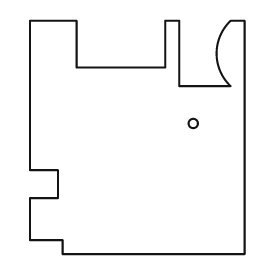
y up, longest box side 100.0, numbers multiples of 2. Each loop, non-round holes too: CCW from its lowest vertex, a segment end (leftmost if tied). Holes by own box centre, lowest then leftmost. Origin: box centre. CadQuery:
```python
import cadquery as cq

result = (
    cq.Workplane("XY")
    .moveTo(-32.0, -50.0)
    .lineTo(46.0, -50.0)
    .lineTo(46.0, 50.0)
    .lineTo(40.0, 50.0)
    .threePointArc((34.0, 36.0), (40.0, 22.0))
    .lineTo(18.0, 22.0)
    .lineTo(18.0, 50.0)
    .lineTo(12.0, 50.0)
    .lineTo(12.0, 30.0)
    .lineTo(-26.0, 30.0)
    .lineTo(-26.0, 50.0)
    .lineTo(-46.0, 50.0)
    .lineTo(-46.0, -14.0)
    .lineTo(-34.0, -14.0)
    .lineTo(-34.0, -26.0)
    .lineTo(-46.0, -26.0)
    .lineTo(-46.0, -44.0)
    .lineTo(-32.0, -44.0)
    .close()
    .moveTo(24.0, 6.0)
    .circle(2.0)
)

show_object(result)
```